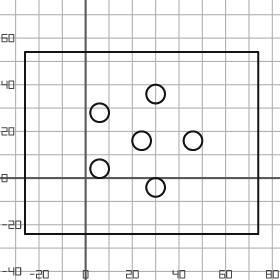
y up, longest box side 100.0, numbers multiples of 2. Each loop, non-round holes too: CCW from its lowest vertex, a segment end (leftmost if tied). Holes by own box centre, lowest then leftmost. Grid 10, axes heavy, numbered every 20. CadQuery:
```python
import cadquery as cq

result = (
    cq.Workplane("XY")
    .moveTo(-26.0, -24.0)
    .lineTo(74.0, -24.0)
    .lineTo(74.0, 54.0)
    .lineTo(-26.0, 54.0)
    .close()
    .moveTo(30.0, -4.0)
    .circle(4.0)
    .moveTo(6.0, 4.0)
    .circle(4.0)
    .moveTo(24.0, 16.0)
    .circle(4.0)
    .moveTo(46.0, 16.0)
    .circle(4.0)
    .moveTo(6.0, 28.0)
    .circle(4.0)
    .moveTo(30.0, 36.0)
    .circle(4.0)
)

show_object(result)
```